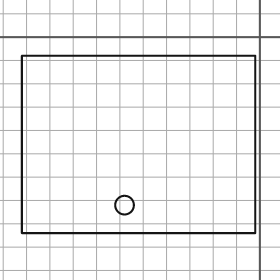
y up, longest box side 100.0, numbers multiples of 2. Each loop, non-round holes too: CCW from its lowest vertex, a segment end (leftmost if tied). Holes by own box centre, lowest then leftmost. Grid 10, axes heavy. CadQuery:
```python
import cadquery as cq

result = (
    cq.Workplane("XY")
    .moveTo(-102.0, -84.0)
    .lineTo(-2.0, -84.0)
    .lineTo(-2.0, -8.0)
    .lineTo(-102.0, -8.0)
    .close()
    .moveTo(-58.0, -72.0)
    .circle(4.0)
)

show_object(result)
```